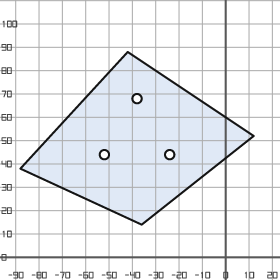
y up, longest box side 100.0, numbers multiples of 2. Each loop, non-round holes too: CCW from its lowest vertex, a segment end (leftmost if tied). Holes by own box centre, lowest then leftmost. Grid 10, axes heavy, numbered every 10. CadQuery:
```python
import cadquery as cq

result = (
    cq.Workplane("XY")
    .moveTo(-36.0, 14.0)
    .lineTo(12.0, 52.0)
    .lineTo(-42.0, 88.0)
    .lineTo(-88.0, 38.0)
    .close()
    .moveTo(-52.0, 44.0)
    .circle(2.0)
    .moveTo(-24.0, 44.0)
    .circle(2.0)
    .moveTo(-38.0, 68.0)
    .circle(2.0)
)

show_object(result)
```